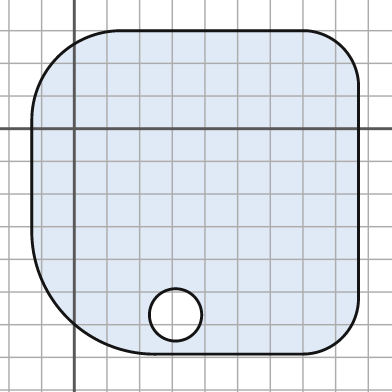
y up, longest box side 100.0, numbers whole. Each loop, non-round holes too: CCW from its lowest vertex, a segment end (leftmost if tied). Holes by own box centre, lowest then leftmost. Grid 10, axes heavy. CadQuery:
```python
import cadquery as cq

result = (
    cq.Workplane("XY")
    .moveTo(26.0, -69.0)
    .lineTo(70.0, -69.0)
    .threePointArc((82.0, -64.0), (87.0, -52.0))
    .lineTo(87.0, 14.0)
    .threePointArc((82.0, 25.0), (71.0, 30.0))
    .lineTo(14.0, 30.0)
    .threePointArc((-5.0, 22.0), (-13.0, 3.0))
    .lineTo(-13.0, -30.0)
    .threePointArc((-2.0, -58.0), (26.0, -69.0))
    .close()
    .moveTo(31.0, -57.0)
    .circle(8.0)
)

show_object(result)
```